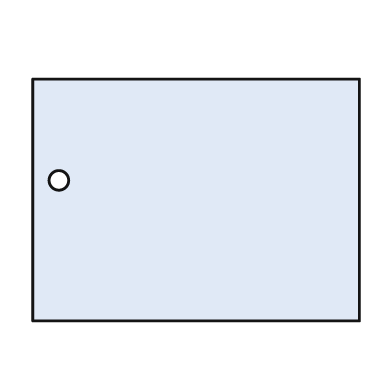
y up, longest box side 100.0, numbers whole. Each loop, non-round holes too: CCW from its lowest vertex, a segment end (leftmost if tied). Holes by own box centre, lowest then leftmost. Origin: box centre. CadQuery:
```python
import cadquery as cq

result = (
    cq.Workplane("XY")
    .moveTo(-50.0, -37.0)
    .lineTo(50.0, -37.0)
    .lineTo(50.0, 37.0)
    .lineTo(-50.0, 37.0)
    .close()
    .moveTo(-42.0, 6.0)
    .circle(3.0)
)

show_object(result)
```